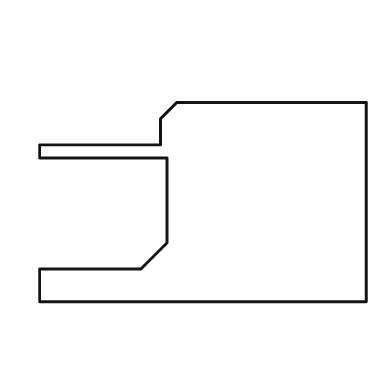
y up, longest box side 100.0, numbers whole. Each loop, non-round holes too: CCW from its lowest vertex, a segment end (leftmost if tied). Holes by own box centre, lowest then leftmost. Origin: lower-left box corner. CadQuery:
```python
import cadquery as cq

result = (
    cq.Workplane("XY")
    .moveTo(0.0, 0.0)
    .lineTo(100.0, 0.0)
    .lineTo(100.0, 61.0)
    .lineTo(42.0, 61.0)
    .lineTo(37.0, 56.0)
    .lineTo(37.0, 48.0)
    .lineTo(0.0, 48.0)
    .lineTo(0.0, 44.0)
    .lineTo(39.0, 44.0)
    .lineTo(39.0, 18.0)
    .lineTo(31.0, 10.0)
    .lineTo(0.0, 10.0)
    .close()
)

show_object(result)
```